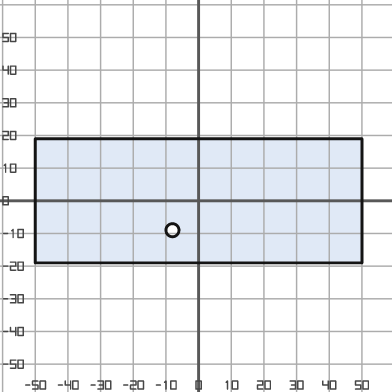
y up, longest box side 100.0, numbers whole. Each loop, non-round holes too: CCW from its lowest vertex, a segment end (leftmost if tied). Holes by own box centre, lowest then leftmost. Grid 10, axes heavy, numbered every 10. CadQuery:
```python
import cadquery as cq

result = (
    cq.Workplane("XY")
    .moveTo(-50.0, -19.0)
    .lineTo(50.0, -19.0)
    .lineTo(50.0, 19.0)
    .lineTo(-50.0, 19.0)
    .close()
    .moveTo(-8.0, -9.0)
    .circle(2.0)
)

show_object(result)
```